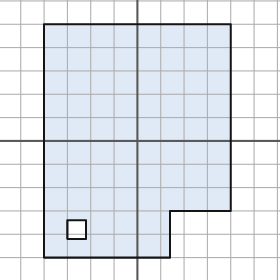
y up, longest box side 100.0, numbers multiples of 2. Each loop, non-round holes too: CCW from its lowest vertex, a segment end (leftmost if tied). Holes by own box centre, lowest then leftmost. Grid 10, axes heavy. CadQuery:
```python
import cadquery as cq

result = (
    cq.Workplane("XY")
    .moveTo(-40.0, -50.0)
    .lineTo(14.0, -50.0)
    .lineTo(14.0, -30.0)
    .lineTo(40.0, -30.0)
    .lineTo(40.0, 50.0)
    .lineTo(-40.0, 50.0)
    .close()
    .moveTo(-30.0, -42.0)
    .lineTo(-22.0, -42.0)
    .lineTo(-22.0, -34.0)
    .lineTo(-30.0, -34.0)
    .close()
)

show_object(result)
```